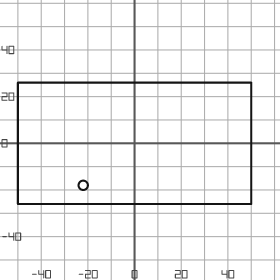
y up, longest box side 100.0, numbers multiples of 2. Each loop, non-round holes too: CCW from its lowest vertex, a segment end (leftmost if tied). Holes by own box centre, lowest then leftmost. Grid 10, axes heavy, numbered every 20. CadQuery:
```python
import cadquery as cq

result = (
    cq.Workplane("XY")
    .moveTo(-50.0, -26.0)
    .lineTo(50.0, -26.0)
    .lineTo(50.0, 26.0)
    .lineTo(-50.0, 26.0)
    .close()
    .moveTo(-22.0, -18.0)
    .circle(2.0)
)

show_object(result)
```